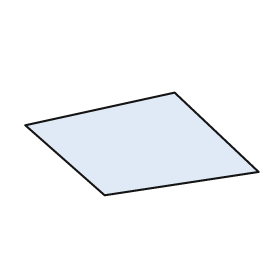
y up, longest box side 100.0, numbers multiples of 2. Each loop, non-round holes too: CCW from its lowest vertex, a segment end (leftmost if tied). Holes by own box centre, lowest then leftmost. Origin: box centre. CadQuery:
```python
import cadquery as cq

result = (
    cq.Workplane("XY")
    .moveTo(-16.0, -22.0)
    .lineTo(50.0, -12.0)
    .lineTo(14.0, 22.0)
    .lineTo(-50.0, 8.0)
    .close()
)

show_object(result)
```